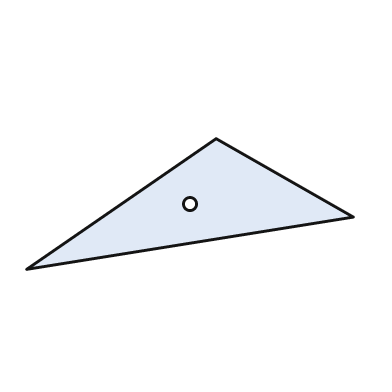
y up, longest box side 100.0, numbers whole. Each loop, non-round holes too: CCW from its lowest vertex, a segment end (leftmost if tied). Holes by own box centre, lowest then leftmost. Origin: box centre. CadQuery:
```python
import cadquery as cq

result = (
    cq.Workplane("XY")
    .moveTo(-50.0, -20.0)
    .lineTo(50.0, -4.0)
    .lineTo(8.0, 20.0)
    .close()
    .moveTo(0.0, 0.0)
    .circle(2.0)
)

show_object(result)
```